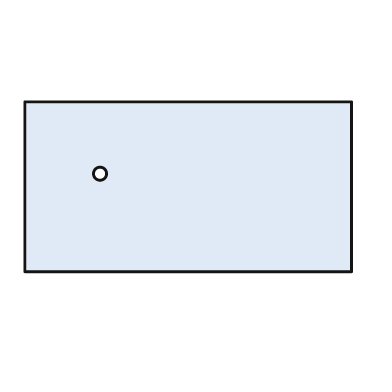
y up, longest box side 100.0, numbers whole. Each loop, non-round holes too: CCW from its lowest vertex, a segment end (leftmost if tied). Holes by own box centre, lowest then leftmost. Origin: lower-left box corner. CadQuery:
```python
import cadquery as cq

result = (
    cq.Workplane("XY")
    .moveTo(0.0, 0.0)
    .lineTo(100.0, 0.0)
    .lineTo(100.0, 52.0)
    .lineTo(0.0, 52.0)
    .close()
    .moveTo(23.0, 30.0)
    .circle(2.0)
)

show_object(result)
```